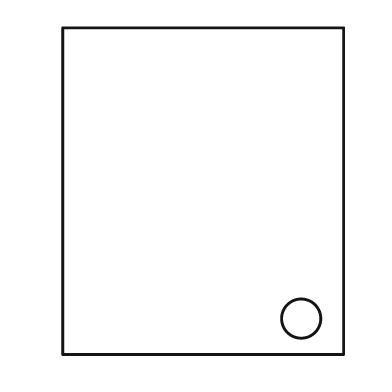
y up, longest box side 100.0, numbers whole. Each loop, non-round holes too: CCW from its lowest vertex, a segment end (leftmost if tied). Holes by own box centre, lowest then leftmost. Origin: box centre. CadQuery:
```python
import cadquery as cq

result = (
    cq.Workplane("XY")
    .moveTo(-43.0, -50.0)
    .lineTo(43.0, -50.0)
    .lineTo(43.0, 50.0)
    .lineTo(-43.0, 50.0)
    .close()
    .moveTo(30.0, -39.0)
    .circle(6.0)
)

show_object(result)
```